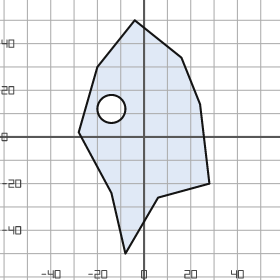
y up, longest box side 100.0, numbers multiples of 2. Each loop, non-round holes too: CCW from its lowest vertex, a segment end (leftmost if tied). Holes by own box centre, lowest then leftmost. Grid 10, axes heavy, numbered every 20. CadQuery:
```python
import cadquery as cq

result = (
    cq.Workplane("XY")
    .moveTo(-8.0, -50.0)
    .lineTo(6.0, -26.0)
    .lineTo(28.0, -20.0)
    .lineTo(24.0, 14.0)
    .lineTo(16.0, 34.0)
    .lineTo(-4.0, 50.0)
    .lineTo(-20.0, 30.0)
    .lineTo(-28.0, 2.0)
    .lineTo(-14.0, -24.0)
    .close()
    .moveTo(-14.0, 12.0)
    .circle(6.0)
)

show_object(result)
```